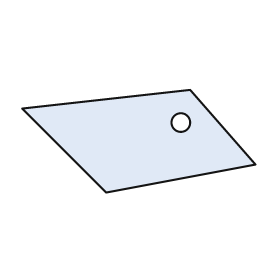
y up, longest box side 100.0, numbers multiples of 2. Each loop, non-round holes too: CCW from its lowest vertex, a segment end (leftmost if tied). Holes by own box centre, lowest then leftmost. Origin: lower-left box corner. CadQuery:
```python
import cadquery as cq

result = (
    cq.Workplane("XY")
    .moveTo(36.0, 0.0)
    .lineTo(100.0, 12.0)
    .lineTo(72.0, 44.0)
    .lineTo(0.0, 36.0)
    .close()
    .moveTo(68.0, 30.0)
    .circle(4.0)
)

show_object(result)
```